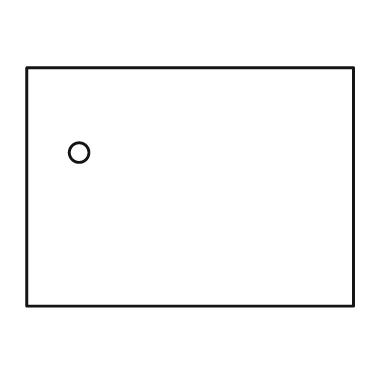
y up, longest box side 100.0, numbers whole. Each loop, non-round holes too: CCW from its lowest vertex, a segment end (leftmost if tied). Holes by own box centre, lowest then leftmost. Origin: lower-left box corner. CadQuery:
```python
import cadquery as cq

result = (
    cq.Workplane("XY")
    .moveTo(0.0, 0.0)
    .lineTo(100.0, 0.0)
    .lineTo(100.0, 73.0)
    .lineTo(0.0, 73.0)
    .close()
    .moveTo(16.0, 47.0)
    .circle(3.0)
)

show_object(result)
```